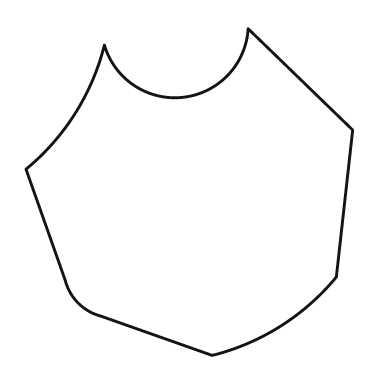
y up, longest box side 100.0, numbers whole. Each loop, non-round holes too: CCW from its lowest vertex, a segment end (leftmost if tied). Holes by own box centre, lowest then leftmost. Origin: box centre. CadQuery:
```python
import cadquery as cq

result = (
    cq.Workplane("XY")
    .moveTo(7.0, -50.0)
    .threePointArc((28.0, -41.0), (45.0, -26.0))
    .lineTo(50.0, 19.0)
    .lineTo(18.0, 50.0)
    .threePointArc((-2.0, 29.0), (-26.0, 45.0))
    .threePointArc((-35.0, 24.0), (-50.0, 7.0))
    .lineTo(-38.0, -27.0)
    .threePointArc((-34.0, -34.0), (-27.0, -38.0))
    .close()
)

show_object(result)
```